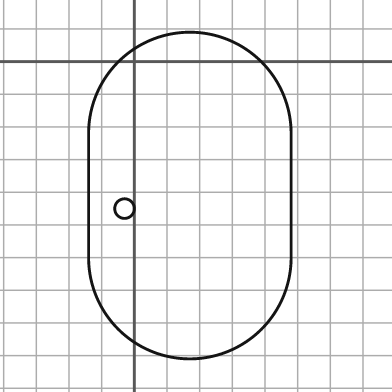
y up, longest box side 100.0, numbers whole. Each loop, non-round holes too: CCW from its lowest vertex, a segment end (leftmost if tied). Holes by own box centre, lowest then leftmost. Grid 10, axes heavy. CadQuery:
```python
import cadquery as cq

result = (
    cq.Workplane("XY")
    .moveTo(-14.0, -60.0)
    .threePointArc((17.0, -91.0), (48.0, -60.0))
    .lineTo(48.0, -22.0)
    .threePointArc((17.0, 9.0), (-14.0, -22.0))
    .close()
    .moveTo(-3.0, -45.0)
    .circle(3.0)
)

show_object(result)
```